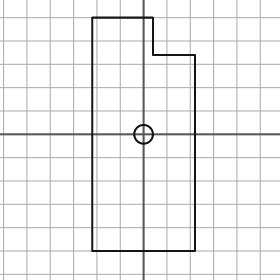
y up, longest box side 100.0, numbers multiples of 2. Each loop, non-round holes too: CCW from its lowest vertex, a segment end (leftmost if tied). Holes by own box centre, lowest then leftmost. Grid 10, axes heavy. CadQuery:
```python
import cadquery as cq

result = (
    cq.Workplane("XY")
    .moveTo(-22.0, -50.0)
    .lineTo(22.0, -50.0)
    .lineTo(22.0, 34.0)
    .lineTo(4.0, 34.0)
    .lineTo(4.0, 50.0)
    .lineTo(-22.0, 50.0)
    .close()
    .moveTo(0.0, 0.0)
    .circle(4.0)
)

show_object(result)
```